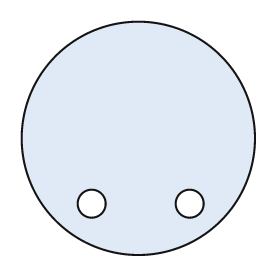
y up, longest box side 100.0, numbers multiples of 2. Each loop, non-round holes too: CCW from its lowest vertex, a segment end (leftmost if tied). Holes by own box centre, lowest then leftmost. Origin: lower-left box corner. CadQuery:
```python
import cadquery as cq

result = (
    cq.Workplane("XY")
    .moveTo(50.0, 50.0)
    .circle(50.0)
    .moveTo(30.0, 22.0)
    .circle(6.0)
    .moveTo(72.0, 22.0)
    .circle(6.0)
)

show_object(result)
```